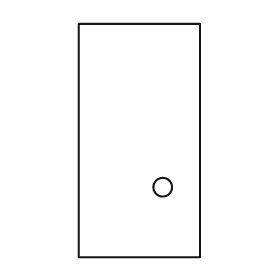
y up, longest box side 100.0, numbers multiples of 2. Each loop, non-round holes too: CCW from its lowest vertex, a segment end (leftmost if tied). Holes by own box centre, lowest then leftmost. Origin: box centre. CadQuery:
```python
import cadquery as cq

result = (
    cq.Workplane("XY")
    .moveTo(-26.0, -50.0)
    .lineTo(26.0, -50.0)
    .lineTo(26.0, 50.0)
    .lineTo(-26.0, 50.0)
    .close()
    .moveTo(10.0, -20.0)
    .circle(4.0)
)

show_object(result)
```